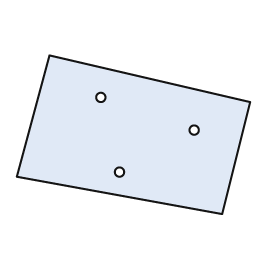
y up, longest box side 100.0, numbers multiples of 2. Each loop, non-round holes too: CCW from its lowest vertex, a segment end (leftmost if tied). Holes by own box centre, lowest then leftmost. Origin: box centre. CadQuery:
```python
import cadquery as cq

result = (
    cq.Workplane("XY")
    .moveTo(38.0, -34.0)
    .lineTo(50.0, 14.0)
    .lineTo(-36.0, 34.0)
    .lineTo(-50.0, -18.0)
    .close()
    .moveTo(-6.0, -16.0)
    .circle(2.0)
    .moveTo(26.0, 2.0)
    .circle(2.0)
    .moveTo(-14.0, 16.0)
    .circle(2.0)
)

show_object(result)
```